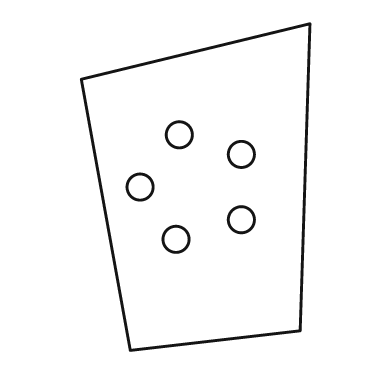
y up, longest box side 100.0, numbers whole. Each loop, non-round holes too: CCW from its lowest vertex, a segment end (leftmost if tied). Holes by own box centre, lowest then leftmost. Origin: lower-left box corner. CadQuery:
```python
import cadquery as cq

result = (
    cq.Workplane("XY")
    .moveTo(15.0, 0.0)
    .lineTo(67.0, 6.0)
    .lineTo(70.0, 100.0)
    .lineTo(0.0, 83.0)
    .close()
    .moveTo(29.0, 34.0)
    .circle(4.0)
    .moveTo(49.0, 40.0)
    .circle(4.0)
    .moveTo(18.0, 50.0)
    .circle(4.0)
    .moveTo(49.0, 60.0)
    .circle(4.0)
    .moveTo(30.0, 66.0)
    .circle(4.0)
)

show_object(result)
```